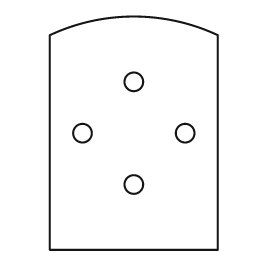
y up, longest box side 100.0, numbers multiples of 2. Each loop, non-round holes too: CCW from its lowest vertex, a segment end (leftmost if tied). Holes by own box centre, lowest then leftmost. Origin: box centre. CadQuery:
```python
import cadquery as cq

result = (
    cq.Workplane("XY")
    .moveTo(-36.0, -50.0)
    .lineTo(36.0, -50.0)
    .lineTo(36.0, 42.0)
    .threePointArc((0.0, 50.0), (-36.0, 42.0))
    .close()
    .moveTo(0.0, -22.0)
    .circle(4.0)
    .moveTo(-22.0, 0.0)
    .circle(4.0)
    .moveTo(22.0, 0.0)
    .circle(4.0)
    .moveTo(0.0, 22.0)
    .circle(4.0)
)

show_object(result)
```